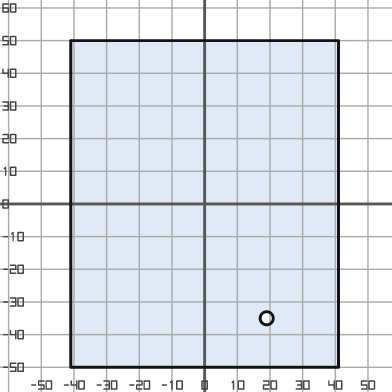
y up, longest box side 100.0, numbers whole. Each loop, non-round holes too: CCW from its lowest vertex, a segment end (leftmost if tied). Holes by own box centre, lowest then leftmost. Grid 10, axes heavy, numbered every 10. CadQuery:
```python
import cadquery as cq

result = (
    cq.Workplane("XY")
    .moveTo(-41.0, -50.0)
    .lineTo(41.0, -50.0)
    .lineTo(41.0, 50.0)
    .lineTo(-41.0, 50.0)
    .close()
    .moveTo(19.0, -35.0)
    .circle(2.0)
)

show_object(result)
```